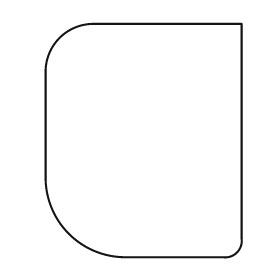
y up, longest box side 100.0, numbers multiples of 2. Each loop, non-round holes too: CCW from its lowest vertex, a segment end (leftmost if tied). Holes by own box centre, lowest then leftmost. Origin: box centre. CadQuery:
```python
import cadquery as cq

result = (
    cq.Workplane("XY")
    .moveTo(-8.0, -50.0)
    .lineTo(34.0, -50.0)
    .threePointArc((40.0, -48.0), (42.0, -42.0))
    .lineTo(42.0, 50.0)
    .lineTo(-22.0, 50.0)
    .threePointArc((-36.0, 44.0), (-42.0, 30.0))
    .lineTo(-42.0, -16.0)
    .threePointArc((-32.0, -40.0), (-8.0, -50.0))
    .close()
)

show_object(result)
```